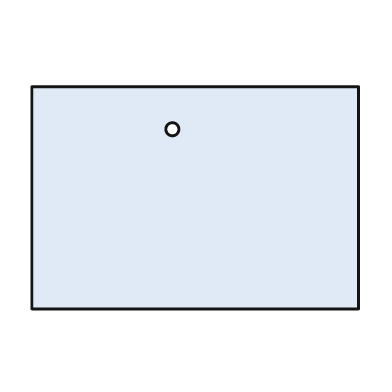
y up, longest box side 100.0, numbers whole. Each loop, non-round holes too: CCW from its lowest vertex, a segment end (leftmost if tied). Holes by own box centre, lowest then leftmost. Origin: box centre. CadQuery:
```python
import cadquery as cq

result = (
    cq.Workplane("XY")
    .moveTo(-50.0, -34.0)
    .lineTo(50.0, -34.0)
    .lineTo(50.0, 34.0)
    .lineTo(-50.0, 34.0)
    .close()
    .moveTo(-7.0, 21.0)
    .circle(2.0)
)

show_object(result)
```